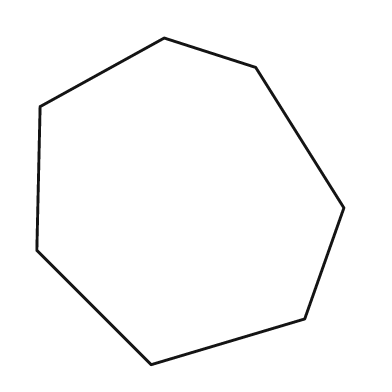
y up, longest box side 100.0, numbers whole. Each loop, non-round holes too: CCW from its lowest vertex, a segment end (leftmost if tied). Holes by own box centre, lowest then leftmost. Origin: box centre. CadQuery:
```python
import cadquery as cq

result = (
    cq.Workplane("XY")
    .moveTo(-12.0, -50.0)
    .lineTo(35.0, -36.0)
    .lineTo(47.0, -2.0)
    .lineTo(20.0, 41.0)
    .lineTo(-8.0, 50.0)
    .lineTo(-46.0, 29.0)
    .lineTo(-47.0, -15.0)
    .close()
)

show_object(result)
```